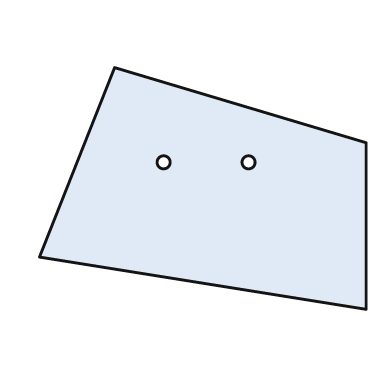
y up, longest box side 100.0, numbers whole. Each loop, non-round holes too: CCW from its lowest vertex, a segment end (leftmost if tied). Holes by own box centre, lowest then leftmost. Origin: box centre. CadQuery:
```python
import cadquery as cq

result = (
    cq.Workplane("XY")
    .moveTo(50.0, -37.0)
    .lineTo(50.0, 14.0)
    .lineTo(-27.0, 37.0)
    .lineTo(-50.0, -21.0)
    .close()
    .moveTo(-12.0, 8.0)
    .circle(2.0)
    .moveTo(14.0, 8.0)
    .circle(2.0)
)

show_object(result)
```